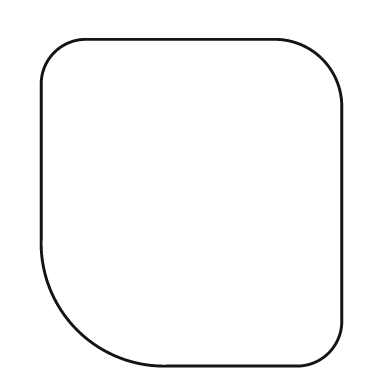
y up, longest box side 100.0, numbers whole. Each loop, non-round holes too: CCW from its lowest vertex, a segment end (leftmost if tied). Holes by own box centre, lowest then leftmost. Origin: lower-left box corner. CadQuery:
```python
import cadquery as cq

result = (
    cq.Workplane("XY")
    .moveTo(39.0, 0.0)
    .lineTo(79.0, 0.0)
    .threePointArc((88.0, 4.0), (92.0, 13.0))
    .lineTo(92.0, 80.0)
    .threePointArc((86.0, 94.0), (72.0, 100.0))
    .lineTo(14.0, 100.0)
    .threePointArc((4.0, 96.0), (0.0, 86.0))
    .lineTo(0.0, 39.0)
    .threePointArc((11.0, 11.0), (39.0, 0.0))
    .close()
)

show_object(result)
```